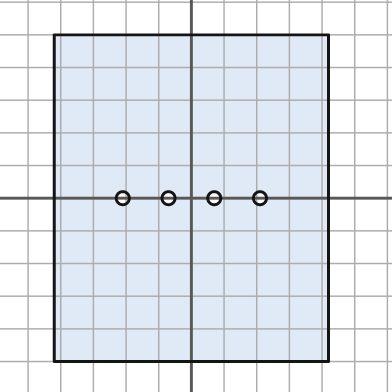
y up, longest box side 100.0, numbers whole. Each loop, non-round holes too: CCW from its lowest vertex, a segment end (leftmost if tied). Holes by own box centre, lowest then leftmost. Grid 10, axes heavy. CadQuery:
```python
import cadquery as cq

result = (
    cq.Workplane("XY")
    .moveTo(-42.0, -50.0)
    .lineTo(42.0, -50.0)
    .lineTo(42.0, 50.0)
    .lineTo(-42.0, 50.0)
    .close()
    .moveTo(-21.0, 0.0)
    .circle(2.0)
    .moveTo(-7.0, 0.0)
    .circle(2.0)
    .moveTo(7.0, 0.0)
    .circle(2.0)
    .moveTo(21.0, 0.0)
    .circle(2.0)
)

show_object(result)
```